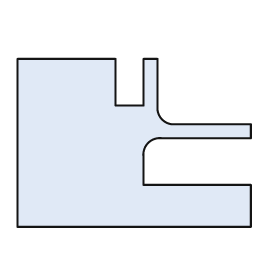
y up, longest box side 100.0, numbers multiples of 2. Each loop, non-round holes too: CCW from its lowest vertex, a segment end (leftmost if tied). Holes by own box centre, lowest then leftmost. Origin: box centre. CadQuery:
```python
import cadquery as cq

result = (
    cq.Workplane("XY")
    .moveTo(-50.0, -36.0)
    .lineTo(50.0, -36.0)
    .lineTo(50.0, -18.0)
    .lineTo(4.0, -18.0)
    .lineTo(4.0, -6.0)
    .threePointArc((6.0, 0.0), (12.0, 2.0))
    .lineTo(50.0, 2.0)
    .lineTo(50.0, 8.0)
    .lineTo(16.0, 8.0)
    .threePointArc((12.0, 10.0), (10.0, 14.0))
    .lineTo(10.0, 36.0)
    .lineTo(4.0, 36.0)
    .lineTo(4.0, 16.0)
    .lineTo(-8.0, 16.0)
    .lineTo(-8.0, 36.0)
    .lineTo(-50.0, 36.0)
    .close()
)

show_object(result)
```